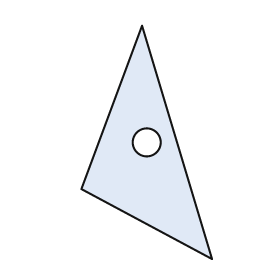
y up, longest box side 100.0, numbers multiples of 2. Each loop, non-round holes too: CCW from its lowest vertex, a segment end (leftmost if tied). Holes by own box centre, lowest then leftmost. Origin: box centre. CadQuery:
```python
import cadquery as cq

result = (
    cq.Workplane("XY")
    .moveTo(28.0, -50.0)
    .lineTo(-2.0, 50.0)
    .lineTo(-28.0, -20.0)
    .close()
    .moveTo(0.0, 0.0)
    .circle(6.0)
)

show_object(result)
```